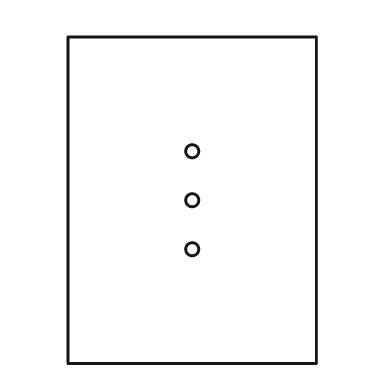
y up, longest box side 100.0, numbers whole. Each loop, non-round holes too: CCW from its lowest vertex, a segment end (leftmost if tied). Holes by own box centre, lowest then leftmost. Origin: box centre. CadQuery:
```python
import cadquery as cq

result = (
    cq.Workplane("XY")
    .moveTo(-38.0, -50.0)
    .lineTo(38.0, -50.0)
    .lineTo(38.0, 50.0)
    .lineTo(-38.0, 50.0)
    .close()
    .moveTo(0.0, -15.0)
    .circle(2.0)
    .moveTo(0.0, 0.0)
    .circle(2.0)
    .moveTo(0.0, 15.0)
    .circle(2.0)
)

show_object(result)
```